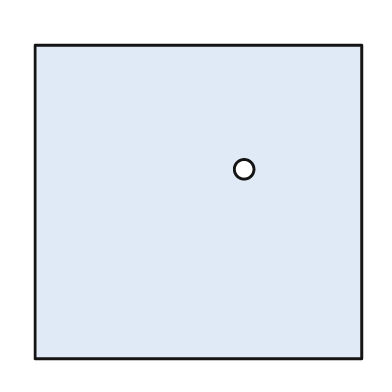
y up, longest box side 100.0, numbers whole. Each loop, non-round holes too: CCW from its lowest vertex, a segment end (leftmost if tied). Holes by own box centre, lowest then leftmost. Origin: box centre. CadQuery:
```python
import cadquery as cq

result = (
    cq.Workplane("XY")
    .moveTo(-50.0, -48.0)
    .lineTo(50.0, -48.0)
    .lineTo(50.0, 48.0)
    .lineTo(-50.0, 48.0)
    .close()
    .moveTo(14.0, 10.0)
    .circle(3.0)
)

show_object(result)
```